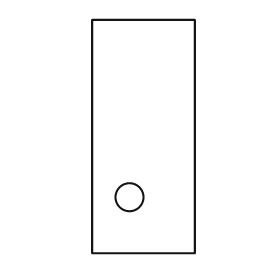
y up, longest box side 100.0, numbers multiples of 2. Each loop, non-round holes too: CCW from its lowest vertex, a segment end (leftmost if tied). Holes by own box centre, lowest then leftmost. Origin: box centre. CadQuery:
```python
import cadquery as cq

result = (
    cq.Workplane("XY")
    .moveTo(-22.0, -50.0)
    .lineTo(22.0, -50.0)
    .lineTo(22.0, 50.0)
    .lineTo(-22.0, 50.0)
    .close()
    .moveTo(-6.0, -26.0)
    .circle(6.0)
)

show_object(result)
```